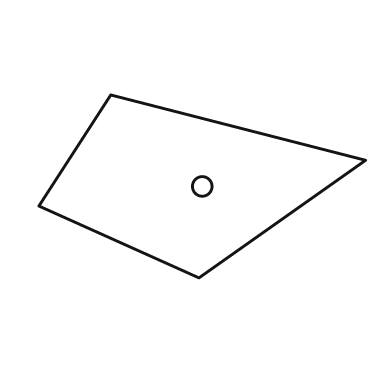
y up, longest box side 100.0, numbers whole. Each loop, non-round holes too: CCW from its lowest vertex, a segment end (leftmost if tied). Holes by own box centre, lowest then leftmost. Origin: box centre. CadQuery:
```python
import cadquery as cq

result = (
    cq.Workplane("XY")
    .moveTo(-1.0, -28.0)
    .lineTo(50.0, 8.0)
    .lineTo(-28.0, 28.0)
    .lineTo(-50.0, -6.0)
    .close()
    .moveTo(0.0, 0.0)
    .circle(3.0)
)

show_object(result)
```